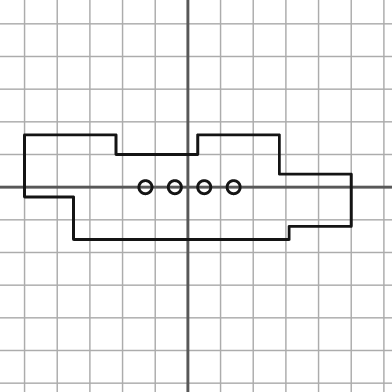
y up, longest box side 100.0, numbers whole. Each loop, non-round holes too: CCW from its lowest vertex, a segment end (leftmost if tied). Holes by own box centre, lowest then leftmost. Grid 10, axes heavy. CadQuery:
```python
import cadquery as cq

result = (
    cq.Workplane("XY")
    .moveTo(-35.0, -16.0)
    .lineTo(31.0, -16.0)
    .lineTo(31.0, -12.0)
    .lineTo(50.0, -12.0)
    .lineTo(50.0, 4.0)
    .lineTo(28.0, 4.0)
    .lineTo(28.0, 16.0)
    .lineTo(3.0, 16.0)
    .lineTo(3.0, 10.0)
    .lineTo(-22.0, 10.0)
    .lineTo(-22.0, 16.0)
    .lineTo(-50.0, 16.0)
    .lineTo(-50.0, -3.0)
    .lineTo(-35.0, -3.0)
    .close()
    .moveTo(-13.0, 0.0)
    .circle(2.0)
    .moveTo(-4.0, 0.0)
    .circle(2.0)
    .moveTo(5.0, 0.0)
    .circle(2.0)
    .moveTo(14.0, 0.0)
    .circle(2.0)
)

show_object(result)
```